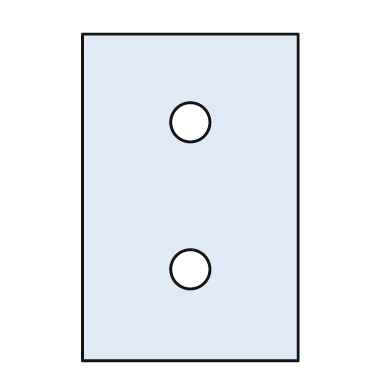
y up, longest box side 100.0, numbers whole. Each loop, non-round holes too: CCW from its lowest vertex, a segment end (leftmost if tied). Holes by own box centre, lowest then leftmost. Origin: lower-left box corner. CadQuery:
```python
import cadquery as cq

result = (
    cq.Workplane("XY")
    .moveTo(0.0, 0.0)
    .lineTo(66.0, 0.0)
    .lineTo(66.0, 100.0)
    .lineTo(0.0, 100.0)
    .close()
    .moveTo(33.0, 28.0)
    .circle(6.0)
    .moveTo(33.0, 73.0)
    .circle(6.0)
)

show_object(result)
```